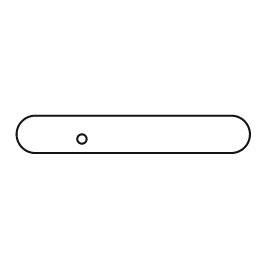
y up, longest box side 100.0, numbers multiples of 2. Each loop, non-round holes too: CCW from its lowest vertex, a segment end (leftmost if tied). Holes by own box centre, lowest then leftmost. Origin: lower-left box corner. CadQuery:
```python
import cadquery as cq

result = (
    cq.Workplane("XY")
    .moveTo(8.0, 0.0)
    .lineTo(92.0, 0.0)
    .threePointArc((100.0, 8.0), (92.0, 16.0))
    .lineTo(8.0, 16.0)
    .threePointArc((0.0, 8.0), (8.0, 0.0))
    .close()
    .moveTo(28.0, 6.0)
    .circle(2.0)
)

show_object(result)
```